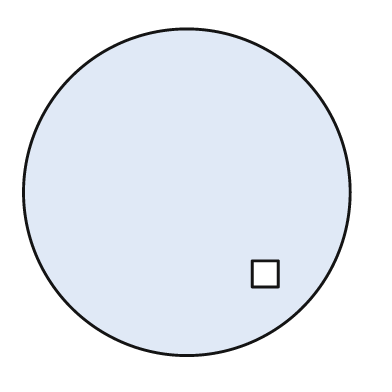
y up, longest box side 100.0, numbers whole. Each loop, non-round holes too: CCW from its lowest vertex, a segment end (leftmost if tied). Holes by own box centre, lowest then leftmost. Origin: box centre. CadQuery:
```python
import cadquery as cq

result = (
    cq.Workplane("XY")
    .moveTo(0.0, 0.0)
    .circle(50.0)
    .moveTo(20.0, -29.0)
    .lineTo(28.0, -29.0)
    .lineTo(28.0, -21.0)
    .lineTo(20.0, -21.0)
    .close()
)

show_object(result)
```